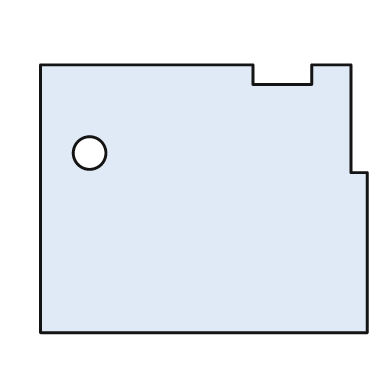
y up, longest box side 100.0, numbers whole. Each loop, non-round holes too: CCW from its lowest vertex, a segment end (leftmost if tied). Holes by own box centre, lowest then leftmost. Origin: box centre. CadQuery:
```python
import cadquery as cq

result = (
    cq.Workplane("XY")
    .moveTo(-50.0, -41.0)
    .lineTo(50.0, -41.0)
    .lineTo(50.0, 8.0)
    .lineTo(45.0, 8.0)
    .lineTo(45.0, 41.0)
    .lineTo(33.0, 41.0)
    .lineTo(33.0, 35.0)
    .lineTo(15.0, 35.0)
    .lineTo(15.0, 41.0)
    .lineTo(-50.0, 41.0)
    .close()
    .moveTo(-35.0, 14.0)
    .circle(5.0)
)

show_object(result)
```